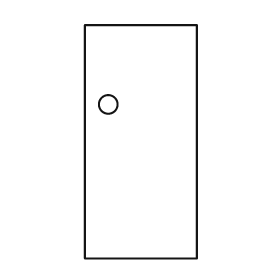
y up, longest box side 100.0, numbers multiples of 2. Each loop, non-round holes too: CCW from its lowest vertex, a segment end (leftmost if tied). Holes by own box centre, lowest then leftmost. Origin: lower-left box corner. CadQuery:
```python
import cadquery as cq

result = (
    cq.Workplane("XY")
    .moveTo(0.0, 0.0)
    .lineTo(48.0, 0.0)
    .lineTo(48.0, 100.0)
    .lineTo(0.0, 100.0)
    .close()
    .moveTo(10.0, 66.0)
    .circle(4.0)
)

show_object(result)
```